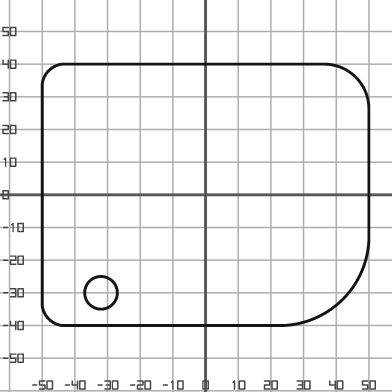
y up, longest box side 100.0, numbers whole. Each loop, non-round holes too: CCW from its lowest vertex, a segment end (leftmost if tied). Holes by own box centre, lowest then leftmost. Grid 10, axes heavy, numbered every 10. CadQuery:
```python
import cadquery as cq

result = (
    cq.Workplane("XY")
    .moveTo(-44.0, -40.0)
    .lineTo(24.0, -40.0)
    .threePointArc((42.0, -32.0), (50.0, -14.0))
    .lineTo(50.0, 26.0)
    .threePointArc((46.0, 36.0), (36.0, 40.0))
    .lineTo(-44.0, 40.0)
    .threePointArc((-48.0, 38.0), (-50.0, 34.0))
    .lineTo(-50.0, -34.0)
    .threePointArc((-48.0, -38.0), (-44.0, -40.0))
    .close()
    .moveTo(-32.0, -30.0)
    .circle(5.0)
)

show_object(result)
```